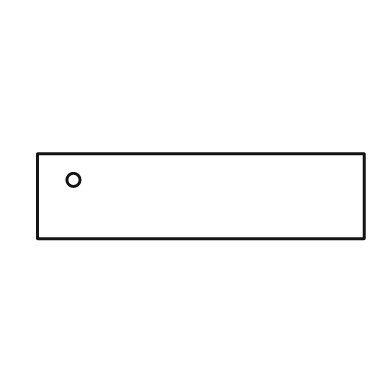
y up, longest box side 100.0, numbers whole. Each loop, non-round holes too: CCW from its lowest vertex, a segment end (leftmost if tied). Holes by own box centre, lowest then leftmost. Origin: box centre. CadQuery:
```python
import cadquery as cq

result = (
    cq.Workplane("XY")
    .moveTo(-50.0, -13.0)
    .lineTo(50.0, -13.0)
    .lineTo(50.0, 13.0)
    .lineTo(-50.0, 13.0)
    .close()
    .moveTo(-39.0, 5.0)
    .circle(2.0)
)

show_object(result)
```